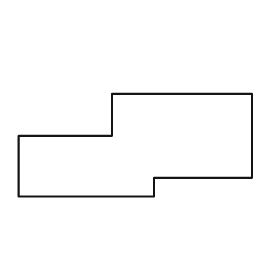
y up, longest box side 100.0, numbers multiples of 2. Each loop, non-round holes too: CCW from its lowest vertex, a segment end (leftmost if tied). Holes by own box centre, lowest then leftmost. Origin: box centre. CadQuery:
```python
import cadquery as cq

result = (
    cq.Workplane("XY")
    .moveTo(-50.0, -22.0)
    .lineTo(8.0, -22.0)
    .lineTo(8.0, -14.0)
    .lineTo(50.0, -14.0)
    .lineTo(50.0, 22.0)
    .lineTo(-10.0, 22.0)
    .lineTo(-10.0, 4.0)
    .lineTo(-50.0, 4.0)
    .close()
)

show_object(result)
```